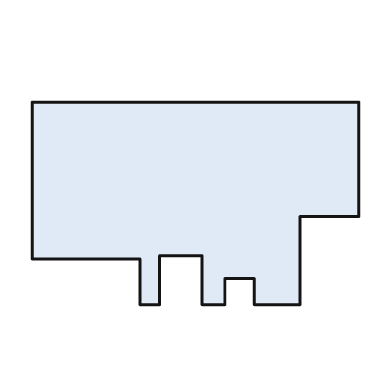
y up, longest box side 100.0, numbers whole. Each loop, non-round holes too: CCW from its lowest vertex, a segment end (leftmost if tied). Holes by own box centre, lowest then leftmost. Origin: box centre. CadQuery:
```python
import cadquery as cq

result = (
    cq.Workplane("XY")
    .moveTo(-17.0, -31.0)
    .lineTo(-11.0, -31.0)
    .lineTo(-11.0, -16.0)
    .lineTo(2.0, -16.0)
    .lineTo(2.0, -31.0)
    .lineTo(9.0, -31.0)
    .lineTo(9.0, -23.0)
    .lineTo(18.0, -23.0)
    .lineTo(18.0, -31.0)
    .lineTo(32.0, -31.0)
    .lineTo(32.0, -4.0)
    .lineTo(50.0, -4.0)
    .lineTo(50.0, 31.0)
    .lineTo(-50.0, 31.0)
    .lineTo(-50.0, -17.0)
    .lineTo(-17.0, -17.0)
    .close()
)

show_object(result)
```